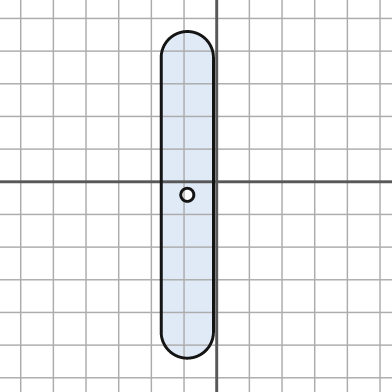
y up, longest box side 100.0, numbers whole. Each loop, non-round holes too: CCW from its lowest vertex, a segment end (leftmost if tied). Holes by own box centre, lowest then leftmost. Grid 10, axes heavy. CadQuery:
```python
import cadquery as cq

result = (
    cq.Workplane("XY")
    .moveTo(-17.0, -46.0)
    .threePointArc((-9.0, -54.0), (-1.0, -46.0))
    .lineTo(-1.0, 38.0)
    .threePointArc((-9.0, 46.0), (-17.0, 38.0))
    .close()
    .moveTo(-9.0, -4.0)
    .circle(2.0)
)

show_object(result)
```